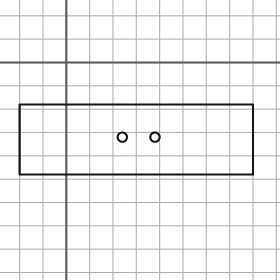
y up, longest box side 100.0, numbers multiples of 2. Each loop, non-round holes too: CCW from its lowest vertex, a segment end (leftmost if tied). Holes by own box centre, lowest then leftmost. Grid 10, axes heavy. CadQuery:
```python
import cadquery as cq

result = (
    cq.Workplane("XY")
    .moveTo(-20.0, -48.0)
    .lineTo(80.0, -48.0)
    .lineTo(80.0, -18.0)
    .lineTo(-20.0, -18.0)
    .close()
    .moveTo(24.0, -32.0)
    .circle(2.0)
    .moveTo(38.0, -32.0)
    .circle(2.0)
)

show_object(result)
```